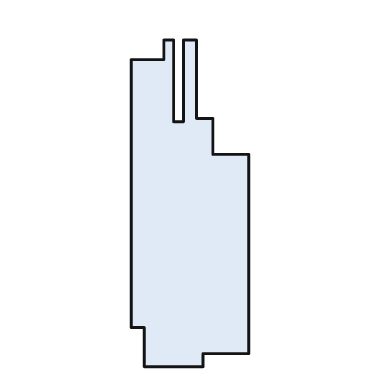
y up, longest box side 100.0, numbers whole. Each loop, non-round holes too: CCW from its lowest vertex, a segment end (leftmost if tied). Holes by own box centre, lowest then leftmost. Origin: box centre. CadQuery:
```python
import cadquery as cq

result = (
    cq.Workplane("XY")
    .moveTo(-14.0, -50.0)
    .lineTo(4.0, -50.0)
    .lineTo(4.0, -46.0)
    .lineTo(18.0, -46.0)
    .lineTo(18.0, 15.0)
    .lineTo(7.0, 15.0)
    .lineTo(7.0, 26.0)
    .lineTo(2.0, 26.0)
    .lineTo(2.0, 50.0)
    .lineTo(-2.0, 50.0)
    .lineTo(-2.0, 25.0)
    .lineTo(-5.0, 25.0)
    .lineTo(-5.0, 50.0)
    .lineTo(-8.0, 50.0)
    .lineTo(-8.0, 44.0)
    .lineTo(-18.0, 44.0)
    .lineTo(-18.0, -38.0)
    .lineTo(-14.0, -38.0)
    .close()
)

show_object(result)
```